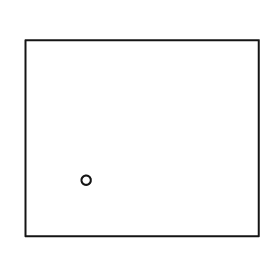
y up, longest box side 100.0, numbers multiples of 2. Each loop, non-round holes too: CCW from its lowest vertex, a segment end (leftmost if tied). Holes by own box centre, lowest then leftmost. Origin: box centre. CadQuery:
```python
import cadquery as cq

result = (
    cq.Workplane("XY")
    .moveTo(-50.0, -42.0)
    .lineTo(50.0, -42.0)
    .lineTo(50.0, 42.0)
    .lineTo(-50.0, 42.0)
    .close()
    .moveTo(-24.0, -18.0)
    .circle(2.0)
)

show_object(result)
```